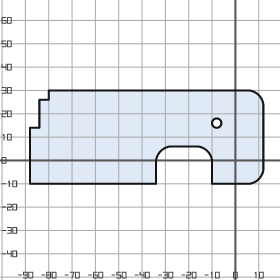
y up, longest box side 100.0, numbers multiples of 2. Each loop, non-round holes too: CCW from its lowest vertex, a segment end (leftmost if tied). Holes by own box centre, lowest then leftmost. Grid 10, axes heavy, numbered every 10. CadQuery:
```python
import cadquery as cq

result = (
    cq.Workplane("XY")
    .moveTo(-88.0, -10.0)
    .lineTo(-34.0, -10.0)
    .lineTo(-34.0, 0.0)
    .threePointArc((-32.0, 4.0), (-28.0, 6.0))
    .lineTo(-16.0, 6.0)
    .threePointArc((-12.0, 4.0), (-10.0, 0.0))
    .lineTo(-10.0, -10.0)
    .lineTo(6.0, -10.0)
    .threePointArc((10.0, -8.0), (12.0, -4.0))
    .lineTo(12.0, 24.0)
    .threePointArc((10.0, 28.0), (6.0, 30.0))
    .lineTo(-80.0, 30.0)
    .lineTo(-80.0, 26.0)
    .lineTo(-84.0, 26.0)
    .lineTo(-84.0, 14.0)
    .lineTo(-88.0, 14.0)
    .close()
    .moveTo(-8.0, 16.0)
    .circle(2.0)
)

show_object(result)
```